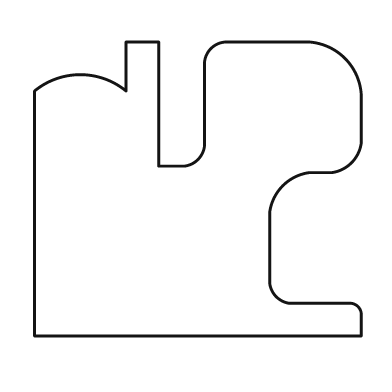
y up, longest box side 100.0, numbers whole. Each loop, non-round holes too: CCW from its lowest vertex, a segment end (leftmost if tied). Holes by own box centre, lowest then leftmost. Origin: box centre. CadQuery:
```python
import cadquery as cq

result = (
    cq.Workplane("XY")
    .moveTo(-50.0, -45.0)
    .lineTo(50.0, -45.0)
    .lineTo(50.0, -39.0)
    .threePointArc((49.0, -36.0), (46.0, -35.0))
    .lineTo(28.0, -35.0)
    .threePointArc((24.0, -33.0), (22.0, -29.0))
    .lineTo(22.0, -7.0)
    .threePointArc((26.0, 1.0), (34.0, 5.0))
    .lineTo(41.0, 5.0)
    .threePointArc((47.0, 8.0), (50.0, 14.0))
    .lineTo(50.0, 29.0)
    .threePointArc((45.0, 40.0), (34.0, 45.0))
    .lineTo(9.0, 45.0)
    .threePointArc((4.0, 43.0), (2.0, 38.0))
    .lineTo(2.0, 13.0)
    .threePointArc((0.0, 9.0), (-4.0, 7.0))
    .lineTo(-12.0, 7.0)
    .lineTo(-12.0, 45.0)
    .lineTo(-22.0, 45.0)
    .lineTo(-22.0, 30.0)
    .threePointArc((-36.0, 35.0), (-50.0, 30.0))
    .close()
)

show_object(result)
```